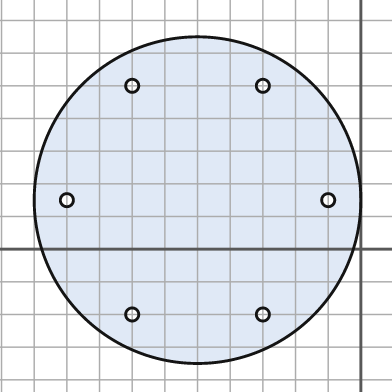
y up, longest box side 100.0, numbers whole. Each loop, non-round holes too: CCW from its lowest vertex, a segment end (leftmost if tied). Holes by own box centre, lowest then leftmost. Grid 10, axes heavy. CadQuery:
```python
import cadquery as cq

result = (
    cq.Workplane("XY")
    .moveTo(-50.0, 15.0)
    .circle(50.0)
    .moveTo(-70.0, -20.0)
    .circle(2.0)
    .moveTo(-30.0, -20.0)
    .circle(2.0)
    .moveTo(-90.0, 15.0)
    .circle(2.0)
    .moveTo(-10.0, 15.0)
    .circle(2.0)
    .moveTo(-70.0, 50.0)
    .circle(2.0)
    .moveTo(-30.0, 50.0)
    .circle(2.0)
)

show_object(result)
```